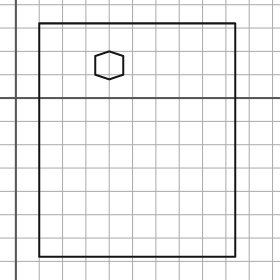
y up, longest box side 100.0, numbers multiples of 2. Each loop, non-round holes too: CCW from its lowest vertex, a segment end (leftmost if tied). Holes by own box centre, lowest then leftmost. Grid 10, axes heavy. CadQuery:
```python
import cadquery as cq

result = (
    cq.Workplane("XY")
    .moveTo(10.0, -68.0)
    .lineTo(94.0, -68.0)
    .lineTo(94.0, 32.0)
    .lineTo(10.0, 32.0)
    .close()
    .moveTo(40.0, 8.0)
    .lineTo(46.0, 10.0)
    .lineTo(46.0, 18.0)
    .lineTo(40.0, 20.0)
    .lineTo(34.0, 18.0)
    .lineTo(34.0, 10.0)
    .close()
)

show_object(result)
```